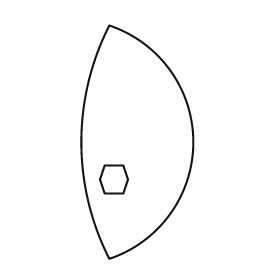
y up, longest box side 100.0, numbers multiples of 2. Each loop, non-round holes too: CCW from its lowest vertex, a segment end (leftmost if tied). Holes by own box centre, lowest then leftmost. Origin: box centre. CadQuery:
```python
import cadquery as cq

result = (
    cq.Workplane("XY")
    .moveTo(-12.0, -50.0)
    .threePointArc((24.0, 0.0), (-12.0, 50.0))
    .threePointArc((-24.0, 0.0), (-12.0, -50.0))
    .close()
    .moveTo(-14.0, -22.0)
    .lineTo(-6.0, -22.0)
    .lineTo(-4.0, -16.0)
    .lineTo(-6.0, -10.0)
    .lineTo(-14.0, -10.0)
    .lineTo(-16.0, -16.0)
    .close()
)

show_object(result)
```